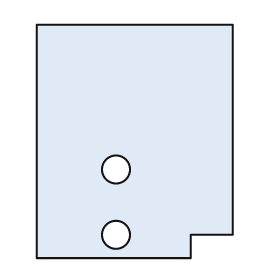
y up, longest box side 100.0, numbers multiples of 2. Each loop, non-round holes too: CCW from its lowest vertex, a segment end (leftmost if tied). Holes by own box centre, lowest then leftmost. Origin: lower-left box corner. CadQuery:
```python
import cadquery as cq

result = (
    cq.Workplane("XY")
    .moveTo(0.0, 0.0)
    .lineTo(66.0, 0.0)
    .lineTo(66.0, 10.0)
    .lineTo(84.0, 10.0)
    .lineTo(84.0, 100.0)
    .lineTo(0.0, 100.0)
    .close()
    .moveTo(34.0, 10.0)
    .circle(6.0)
    .moveTo(34.0, 38.0)
    .circle(6.0)
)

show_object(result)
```